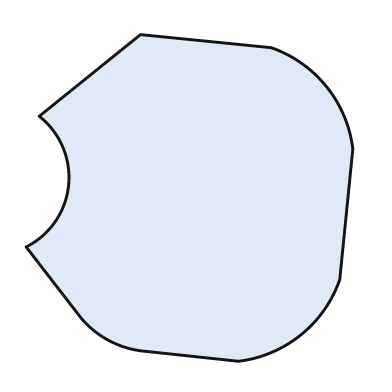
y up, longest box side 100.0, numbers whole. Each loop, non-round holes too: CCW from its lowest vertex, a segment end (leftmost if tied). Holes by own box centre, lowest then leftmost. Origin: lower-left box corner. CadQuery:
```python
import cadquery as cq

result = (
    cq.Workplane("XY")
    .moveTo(65.0, 0.0)
    .threePointArc((84.0, 8.0), (96.0, 25.0))
    .lineTo(100.0, 65.0)
    .threePointArc((92.0, 84.0), (75.0, 96.0))
    .lineTo(35.0, 100.0)
    .lineTo(4.0, 75.0)
    .threePointArc((13.0, 54.0), (0.0, 35.0))
    .lineTo(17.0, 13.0)
    .threePointArc((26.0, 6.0), (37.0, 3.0))
    .close()
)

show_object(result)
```